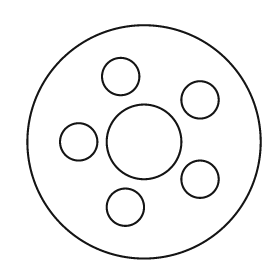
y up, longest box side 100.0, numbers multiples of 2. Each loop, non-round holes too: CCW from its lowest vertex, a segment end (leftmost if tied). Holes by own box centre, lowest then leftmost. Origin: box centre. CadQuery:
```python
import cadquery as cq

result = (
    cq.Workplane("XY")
    .moveTo(0.0, 0.0)
    .circle(50.0)
    .moveTo(-8.0, -28.0)
    .circle(8.0)
    .moveTo(24.0, -16.0)
    .circle(8.0)
    .moveTo(-28.0, 0.0)
    .circle(8.0)
    .moveTo(0.0, 0.0)
    .circle(16.0)
    .moveTo(24.0, 18.0)
    .circle(8.0)
    .moveTo(-10.0, 28.0)
    .circle(8.0)
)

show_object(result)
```